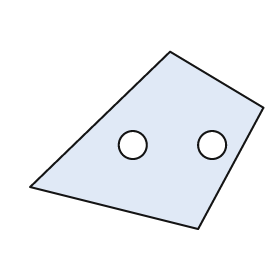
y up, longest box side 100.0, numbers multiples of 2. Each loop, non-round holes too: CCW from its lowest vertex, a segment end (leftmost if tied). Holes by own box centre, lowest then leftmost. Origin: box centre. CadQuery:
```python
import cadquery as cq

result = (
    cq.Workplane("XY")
    .moveTo(22.0, -38.0)
    .lineTo(50.0, 14.0)
    .lineTo(10.0, 38.0)
    .lineTo(-50.0, -20.0)
    .close()
    .moveTo(-6.0, -2.0)
    .circle(6.0)
    .moveTo(28.0, -2.0)
    .circle(6.0)
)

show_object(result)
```